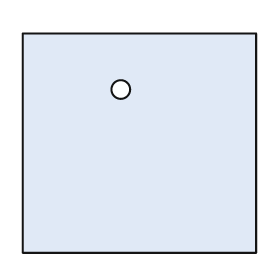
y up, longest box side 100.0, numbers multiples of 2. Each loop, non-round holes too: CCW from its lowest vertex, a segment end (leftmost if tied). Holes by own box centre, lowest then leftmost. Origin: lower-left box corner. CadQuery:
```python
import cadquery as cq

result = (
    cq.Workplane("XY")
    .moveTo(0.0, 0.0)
    .lineTo(100.0, 0.0)
    .lineTo(100.0, 94.0)
    .lineTo(0.0, 94.0)
    .close()
    .moveTo(42.0, 70.0)
    .circle(4.0)
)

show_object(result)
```